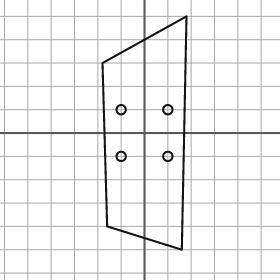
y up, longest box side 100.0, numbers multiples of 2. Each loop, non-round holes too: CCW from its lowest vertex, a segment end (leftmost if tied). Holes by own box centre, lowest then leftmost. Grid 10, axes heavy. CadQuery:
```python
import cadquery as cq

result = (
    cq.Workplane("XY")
    .moveTo(16.0, -50.0)
    .lineTo(18.0, 50.0)
    .lineTo(-18.0, 30.0)
    .lineTo(-16.0, -40.0)
    .close()
    .moveTo(-10.0, -10.0)
    .circle(2.0)
    .moveTo(10.0, -10.0)
    .circle(2.0)
    .moveTo(-10.0, 10.0)
    .circle(2.0)
    .moveTo(10.0, 10.0)
    .circle(2.0)
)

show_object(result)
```